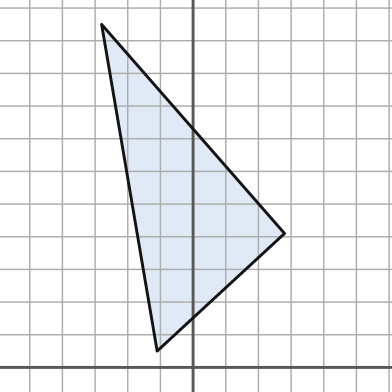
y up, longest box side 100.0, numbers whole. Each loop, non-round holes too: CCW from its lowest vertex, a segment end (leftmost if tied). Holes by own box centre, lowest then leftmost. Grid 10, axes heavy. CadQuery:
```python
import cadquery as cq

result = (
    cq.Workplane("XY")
    .moveTo(-11.0, 5.0)
    .lineTo(28.0, 41.0)
    .lineTo(-28.0, 105.0)
    .close()
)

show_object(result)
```